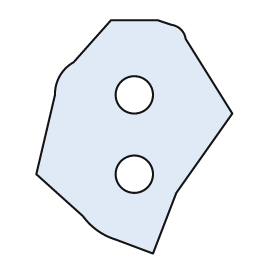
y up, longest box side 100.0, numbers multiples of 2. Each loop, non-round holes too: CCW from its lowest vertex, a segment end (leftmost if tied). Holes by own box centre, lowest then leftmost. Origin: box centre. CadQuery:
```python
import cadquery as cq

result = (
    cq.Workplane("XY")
    .moveTo(8.0, -50.0)
    .lineTo(18.0, -24.0)
    .lineTo(42.0, 10.0)
    .lineTo(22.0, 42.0)
    .threePointArc((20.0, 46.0), (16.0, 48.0))
    .lineTo(10.0, 50.0)
    .lineTo(-10.0, 50.0)
    .lineTo(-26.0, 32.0)
    .threePointArc((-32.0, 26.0), (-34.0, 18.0))
    .lineTo(-42.0, -16.0)
    .lineTo(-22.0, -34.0)
    .threePointArc((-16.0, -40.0), (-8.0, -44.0))
    .close()
    .moveTo(0.0, -16.0)
    .circle(8.0)
    .moveTo(0.0, 18.0)
    .circle(8.0)
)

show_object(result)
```